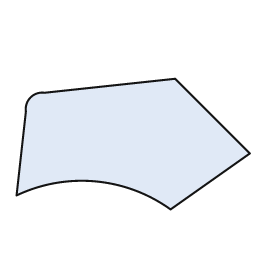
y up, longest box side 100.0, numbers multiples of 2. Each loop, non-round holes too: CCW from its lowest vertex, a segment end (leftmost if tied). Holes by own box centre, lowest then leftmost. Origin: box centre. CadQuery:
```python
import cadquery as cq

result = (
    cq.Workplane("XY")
    .moveTo(16.0, -28.0)
    .lineTo(50.0, -4.0)
    .lineTo(18.0, 28.0)
    .lineTo(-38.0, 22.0)
    .threePointArc((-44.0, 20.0), (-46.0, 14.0))
    .lineTo(-50.0, -22.0)
    .threePointArc((-16.0, -16.0), (16.0, -28.0))
    .close()
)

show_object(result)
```